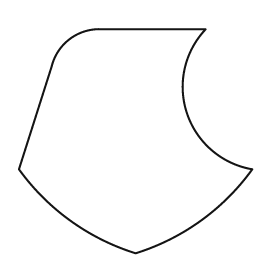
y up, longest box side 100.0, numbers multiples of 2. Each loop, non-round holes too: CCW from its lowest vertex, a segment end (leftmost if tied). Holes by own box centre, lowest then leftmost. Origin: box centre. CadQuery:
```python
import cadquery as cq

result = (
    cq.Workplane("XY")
    .moveTo(0.0, -48.0)
    .threePointArc((28.0, -34.0), (50.0, -12.0))
    .threePointArc((22.0, 12.0), (30.0, 48.0))
    .lineTo(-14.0, 48.0)
    .threePointArc((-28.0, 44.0), (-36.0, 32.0))
    .lineTo(-50.0, -12.0)
    .threePointArc((-28.0, -34.0), (0.0, -48.0))
    .close()
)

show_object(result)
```